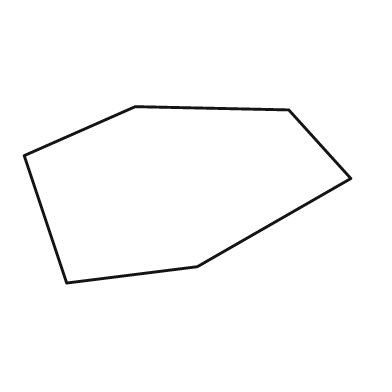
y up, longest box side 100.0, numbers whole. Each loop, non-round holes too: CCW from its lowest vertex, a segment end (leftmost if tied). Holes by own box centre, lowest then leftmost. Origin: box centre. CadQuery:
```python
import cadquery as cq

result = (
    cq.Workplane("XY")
    .moveTo(-37.0, -27.0)
    .lineTo(3.0, -22.0)
    .lineTo(50.0, 5.0)
    .lineTo(31.0, 26.0)
    .lineTo(-16.0, 27.0)
    .lineTo(-50.0, 12.0)
    .close()
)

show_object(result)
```